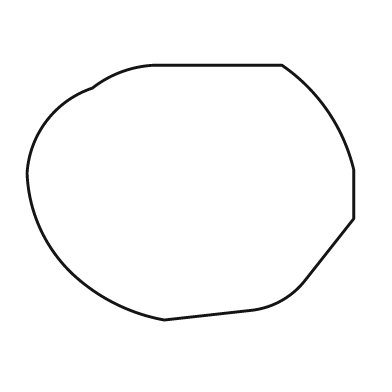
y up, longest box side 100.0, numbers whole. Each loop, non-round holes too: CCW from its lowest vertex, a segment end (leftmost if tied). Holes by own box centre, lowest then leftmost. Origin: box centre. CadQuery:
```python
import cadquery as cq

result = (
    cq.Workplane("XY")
    .moveTo(-8.0, -39.0)
    .lineTo(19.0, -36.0)
    .threePointArc((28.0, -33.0), (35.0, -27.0))
    .lineTo(50.0, -8.0)
    .lineTo(50.0, 7.0)
    .threePointArc((42.0, 25.0), (28.0, 39.0))
    .lineTo(-11.0, 39.0)
    .threePointArc((-21.0, 37.0), (-30.0, 32.0))
    .threePointArc((-44.0, 22.0), (-50.0, 6.0))
    .threePointArc((-46.0, -11.0), (-36.0, -25.0))
    .threePointArc((-23.0, -34.0), (-8.0, -39.0))
    .close()
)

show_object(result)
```